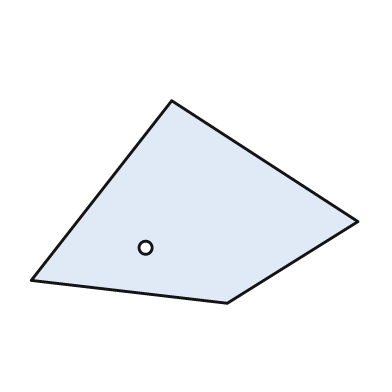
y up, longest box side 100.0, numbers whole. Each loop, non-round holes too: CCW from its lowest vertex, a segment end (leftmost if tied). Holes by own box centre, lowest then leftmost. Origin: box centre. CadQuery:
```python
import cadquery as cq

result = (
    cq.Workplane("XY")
    .moveTo(10.0, -31.0)
    .lineTo(50.0, -6.0)
    .lineTo(-7.0, 31.0)
    .lineTo(-50.0, -24.0)
    .close()
    .moveTo(-15.0, -14.0)
    .circle(2.0)
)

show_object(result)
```